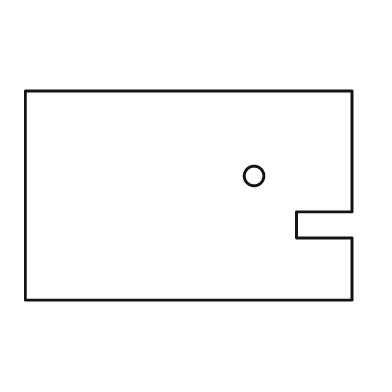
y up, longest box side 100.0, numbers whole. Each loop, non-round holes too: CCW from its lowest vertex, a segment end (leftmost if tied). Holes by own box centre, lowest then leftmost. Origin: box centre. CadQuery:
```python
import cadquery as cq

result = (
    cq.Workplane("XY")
    .moveTo(-50.0, -32.0)
    .lineTo(50.0, -32.0)
    .lineTo(50.0, -13.0)
    .lineTo(33.0, -13.0)
    .lineTo(33.0, -5.0)
    .lineTo(50.0, -5.0)
    .lineTo(50.0, 32.0)
    .lineTo(-50.0, 32.0)
    .close()
    .moveTo(20.0, 6.0)
    .circle(3.0)
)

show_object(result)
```